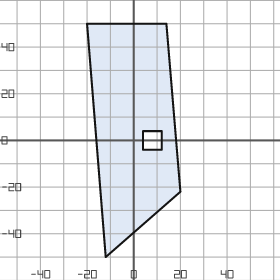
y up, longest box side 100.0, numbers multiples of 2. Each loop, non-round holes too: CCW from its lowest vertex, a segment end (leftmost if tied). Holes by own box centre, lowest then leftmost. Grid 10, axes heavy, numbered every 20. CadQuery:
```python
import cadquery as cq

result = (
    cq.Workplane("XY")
    .moveTo(-12.0, -50.0)
    .lineTo(20.0, -22.0)
    .lineTo(14.0, 50.0)
    .lineTo(-20.0, 50.0)
    .close()
    .moveTo(4.0, -4.0)
    .lineTo(12.0, -4.0)
    .lineTo(12.0, 4.0)
    .lineTo(4.0, 4.0)
    .close()
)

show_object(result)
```